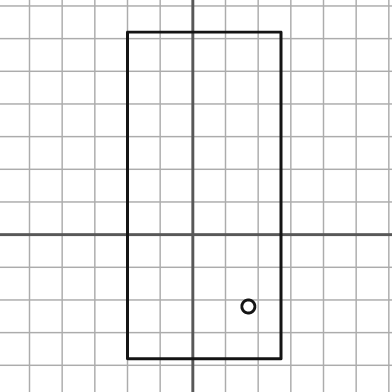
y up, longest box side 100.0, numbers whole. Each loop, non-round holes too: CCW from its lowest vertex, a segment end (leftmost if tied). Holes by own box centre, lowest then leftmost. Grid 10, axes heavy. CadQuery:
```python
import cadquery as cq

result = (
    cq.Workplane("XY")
    .moveTo(-20.0, -38.0)
    .lineTo(27.0, -38.0)
    .lineTo(27.0, 62.0)
    .lineTo(-20.0, 62.0)
    .close()
    .moveTo(17.0, -22.0)
    .circle(2.0)
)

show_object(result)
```